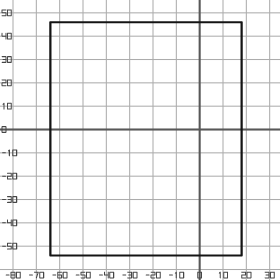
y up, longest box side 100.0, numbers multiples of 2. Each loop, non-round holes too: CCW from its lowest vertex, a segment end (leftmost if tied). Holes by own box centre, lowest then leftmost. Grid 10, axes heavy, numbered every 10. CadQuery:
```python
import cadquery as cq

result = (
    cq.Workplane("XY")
    .moveTo(-64.0, -54.0)
    .lineTo(18.0, -54.0)
    .lineTo(18.0, 46.0)
    .lineTo(-64.0, 46.0)
    .close()
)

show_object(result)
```